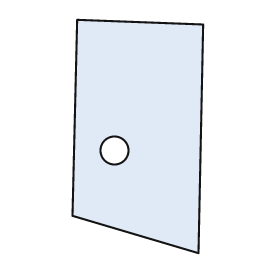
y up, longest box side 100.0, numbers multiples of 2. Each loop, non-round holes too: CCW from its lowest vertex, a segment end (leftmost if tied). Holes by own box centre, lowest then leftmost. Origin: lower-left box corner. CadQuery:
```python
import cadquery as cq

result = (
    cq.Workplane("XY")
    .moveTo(54.0, 0.0)
    .lineTo(56.0, 98.0)
    .lineTo(2.0, 100.0)
    .lineTo(0.0, 16.0)
    .close()
    .moveTo(18.0, 44.0)
    .circle(6.0)
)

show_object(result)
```